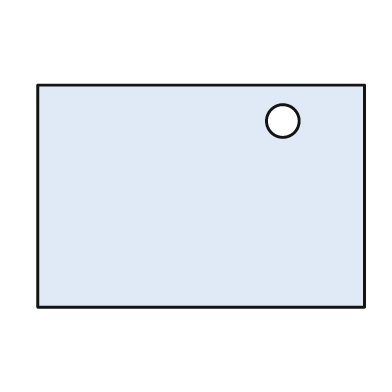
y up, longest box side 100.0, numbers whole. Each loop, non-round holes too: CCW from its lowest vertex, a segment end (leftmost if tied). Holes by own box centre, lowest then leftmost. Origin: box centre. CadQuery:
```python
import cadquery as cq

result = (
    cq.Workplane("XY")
    .moveTo(-50.0, -34.0)
    .lineTo(50.0, -34.0)
    .lineTo(50.0, 34.0)
    .lineTo(-50.0, 34.0)
    .close()
    .moveTo(25.0, 23.0)
    .circle(5.0)
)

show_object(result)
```